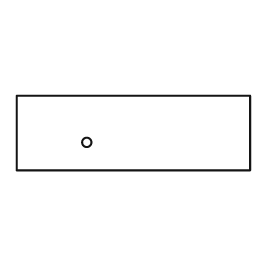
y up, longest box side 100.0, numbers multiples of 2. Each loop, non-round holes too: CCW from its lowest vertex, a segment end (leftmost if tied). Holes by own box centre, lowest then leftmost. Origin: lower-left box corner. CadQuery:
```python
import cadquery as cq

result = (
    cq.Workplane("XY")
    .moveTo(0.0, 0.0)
    .lineTo(100.0, 0.0)
    .lineTo(100.0, 32.0)
    .lineTo(0.0, 32.0)
    .close()
    .moveTo(30.0, 12.0)
    .circle(2.0)
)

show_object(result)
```